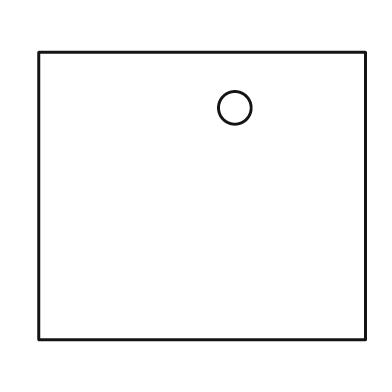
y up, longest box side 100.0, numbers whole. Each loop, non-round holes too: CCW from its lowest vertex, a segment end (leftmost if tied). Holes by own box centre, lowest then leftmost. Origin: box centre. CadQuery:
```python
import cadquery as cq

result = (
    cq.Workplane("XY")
    .moveTo(-50.0, -44.0)
    .lineTo(50.0, -44.0)
    .lineTo(50.0, 44.0)
    .lineTo(-50.0, 44.0)
    .close()
    .moveTo(10.0, 27.0)
    .circle(5.0)
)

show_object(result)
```